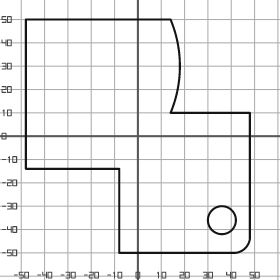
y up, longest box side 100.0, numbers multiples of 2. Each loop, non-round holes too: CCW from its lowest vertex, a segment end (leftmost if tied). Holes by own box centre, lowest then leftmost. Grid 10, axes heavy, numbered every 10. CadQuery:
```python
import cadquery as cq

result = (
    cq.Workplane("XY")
    .moveTo(-8.0, -50.0)
    .lineTo(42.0, -50.0)
    .threePointArc((46.0, -48.0), (48.0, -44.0))
    .lineTo(48.0, 10.0)
    .lineTo(14.0, 10.0)
    .threePointArc((18.0, 30.0), (14.0, 50.0))
    .lineTo(-48.0, 50.0)
    .lineTo(-48.0, -14.0)
    .lineTo(-8.0, -14.0)
    .close()
    .moveTo(36.0, -36.0)
    .circle(6.0)
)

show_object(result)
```